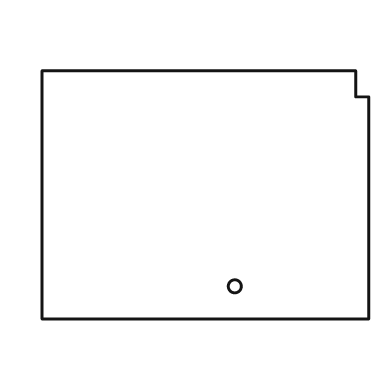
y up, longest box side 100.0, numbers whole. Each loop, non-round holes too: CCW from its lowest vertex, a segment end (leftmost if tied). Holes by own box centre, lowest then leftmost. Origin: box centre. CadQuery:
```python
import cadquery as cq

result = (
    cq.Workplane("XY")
    .moveTo(-50.0, -38.0)
    .lineTo(50.0, -38.0)
    .lineTo(50.0, 30.0)
    .lineTo(46.0, 30.0)
    .lineTo(46.0, 38.0)
    .lineTo(-50.0, 38.0)
    .close()
    .moveTo(9.0, -28.0)
    .circle(2.0)
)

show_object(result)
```